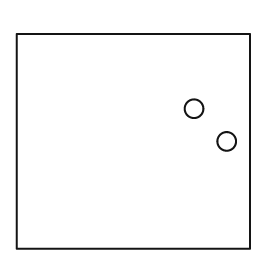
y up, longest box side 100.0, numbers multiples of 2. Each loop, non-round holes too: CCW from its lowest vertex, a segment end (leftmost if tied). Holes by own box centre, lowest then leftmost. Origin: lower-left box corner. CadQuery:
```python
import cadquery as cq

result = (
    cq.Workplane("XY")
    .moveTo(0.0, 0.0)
    .lineTo(100.0, 0.0)
    .lineTo(100.0, 92.0)
    .lineTo(0.0, 92.0)
    .close()
    .moveTo(90.0, 46.0)
    .circle(4.0)
    .moveTo(76.0, 60.0)
    .circle(4.0)
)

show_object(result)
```